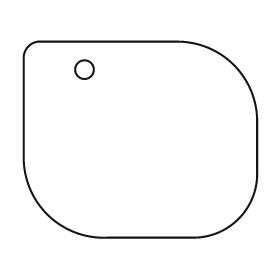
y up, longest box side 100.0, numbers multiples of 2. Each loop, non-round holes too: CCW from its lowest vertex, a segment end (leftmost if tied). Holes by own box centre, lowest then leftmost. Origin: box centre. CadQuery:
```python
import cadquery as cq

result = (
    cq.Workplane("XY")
    .moveTo(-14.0, -42.0)
    .lineTo(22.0, -42.0)
    .threePointArc((42.0, -34.0), (50.0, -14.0))
    .lineTo(50.0, 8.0)
    .threePointArc((40.0, 32.0), (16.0, 42.0))
    .lineTo(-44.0, 42.0)
    .threePointArc((-48.0, 40.0), (-50.0, 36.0))
    .lineTo(-50.0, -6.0)
    .threePointArc((-40.0, -32.0), (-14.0, -42.0))
    .close()
    .moveTo(-24.0, 30.0)
    .circle(4.0)
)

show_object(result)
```